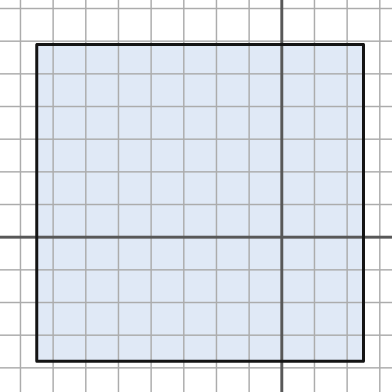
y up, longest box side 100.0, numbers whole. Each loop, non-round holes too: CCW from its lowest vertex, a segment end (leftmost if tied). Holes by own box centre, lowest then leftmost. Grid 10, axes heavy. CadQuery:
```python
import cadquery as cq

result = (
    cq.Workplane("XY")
    .moveTo(-75.0, -38.0)
    .lineTo(25.0, -38.0)
    .lineTo(25.0, 59.0)
    .lineTo(-75.0, 59.0)
    .close()
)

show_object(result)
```